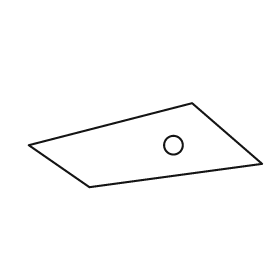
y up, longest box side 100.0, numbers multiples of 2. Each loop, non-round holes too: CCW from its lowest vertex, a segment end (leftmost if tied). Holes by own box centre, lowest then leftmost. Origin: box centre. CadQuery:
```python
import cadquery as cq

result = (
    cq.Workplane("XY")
    .moveTo(-24.0, -18.0)
    .lineTo(50.0, -8.0)
    .lineTo(20.0, 18.0)
    .lineTo(-50.0, 0.0)
    .close()
    .moveTo(12.0, 0.0)
    .circle(4.0)
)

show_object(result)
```